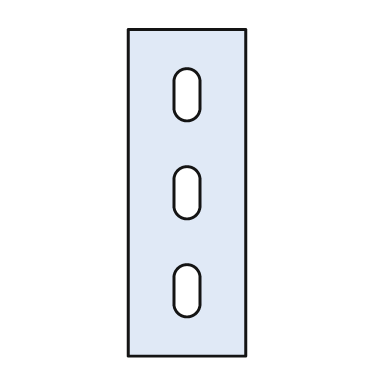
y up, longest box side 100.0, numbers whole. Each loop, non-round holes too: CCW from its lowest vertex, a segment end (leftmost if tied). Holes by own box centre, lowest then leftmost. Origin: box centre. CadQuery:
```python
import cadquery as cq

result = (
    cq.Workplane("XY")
    .moveTo(-18.0, -50.0)
    .lineTo(18.0, -50.0)
    .lineTo(18.0, 50.0)
    .lineTo(-18.0, 50.0)
    .close()
    .moveTo(-4.0, -34.0)
    .threePointArc((0.0, -38.0), (4.0, -34.0))
    .lineTo(4.0, -26.0)
    .threePointArc((0.0, -22.0), (-4.0, -26.0))
    .close()
    .moveTo(-4.0, -4.0)
    .threePointArc((0.0, -8.0), (4.0, -4.0))
    .lineTo(4.0, 4.0)
    .threePointArc((0.0, 8.0), (-4.0, 4.0))
    .close()
    .moveTo(-4.0, 26.0)
    .threePointArc((0.0, 22.0), (4.0, 26.0))
    .lineTo(4.0, 34.0)
    .threePointArc((0.0, 38.0), (-4.0, 34.0))
    .close()
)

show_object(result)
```